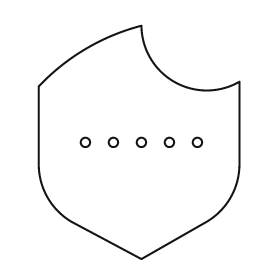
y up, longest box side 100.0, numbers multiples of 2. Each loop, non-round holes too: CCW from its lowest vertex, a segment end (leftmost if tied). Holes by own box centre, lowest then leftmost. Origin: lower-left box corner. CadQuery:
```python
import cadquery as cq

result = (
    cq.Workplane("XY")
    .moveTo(44.0, 0.0)
    .lineTo(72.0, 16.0)
    .threePointArc((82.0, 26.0), (86.0, 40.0))
    .lineTo(86.0, 76.0)
    .threePointArc((58.0, 76.0), (44.0, 100.0))
    .threePointArc((20.0, 90.0), (0.0, 74.0))
    .lineTo(0.0, 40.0)
    .threePointArc((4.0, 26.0), (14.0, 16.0))
    .close()
    .moveTo(20.0, 50.0)
    .circle(2.0)
    .moveTo(32.0, 50.0)
    .circle(2.0)
    .moveTo(44.0, 50.0)
    .circle(2.0)
    .moveTo(56.0, 50.0)
    .circle(2.0)
    .moveTo(68.0, 50.0)
    .circle(2.0)
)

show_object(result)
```